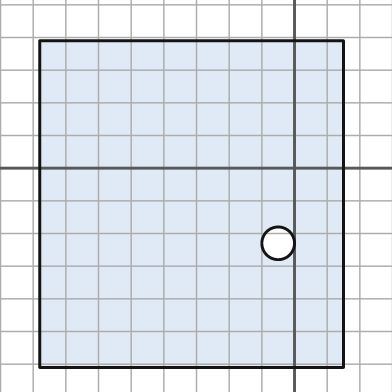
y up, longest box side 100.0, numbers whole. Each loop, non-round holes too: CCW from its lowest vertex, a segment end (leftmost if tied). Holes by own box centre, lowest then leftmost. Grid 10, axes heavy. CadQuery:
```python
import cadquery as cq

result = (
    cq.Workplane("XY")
    .moveTo(-78.0, -61.0)
    .lineTo(15.0, -61.0)
    .lineTo(15.0, 39.0)
    .lineTo(-78.0, 39.0)
    .close()
    .moveTo(-5.0, -23.0)
    .circle(5.0)
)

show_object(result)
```